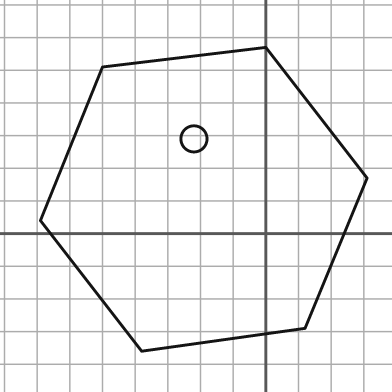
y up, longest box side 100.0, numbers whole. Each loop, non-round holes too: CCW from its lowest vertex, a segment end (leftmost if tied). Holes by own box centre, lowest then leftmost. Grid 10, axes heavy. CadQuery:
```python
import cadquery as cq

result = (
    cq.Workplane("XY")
    .moveTo(-38.0, -36.0)
    .lineTo(12.0, -29.0)
    .lineTo(31.0, 17.0)
    .lineTo(0.0, 57.0)
    .lineTo(-50.0, 51.0)
    .lineTo(-69.0, 4.0)
    .close()
    .moveTo(-22.0, 29.0)
    .circle(4.0)
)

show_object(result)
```